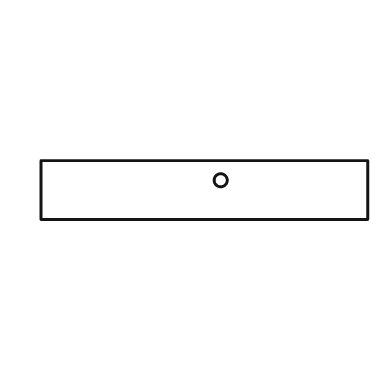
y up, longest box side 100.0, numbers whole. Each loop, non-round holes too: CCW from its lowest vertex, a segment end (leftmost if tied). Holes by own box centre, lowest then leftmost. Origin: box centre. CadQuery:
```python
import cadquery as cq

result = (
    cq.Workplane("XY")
    .moveTo(-50.0, -9.0)
    .lineTo(50.0, -9.0)
    .lineTo(50.0, 9.0)
    .lineTo(-50.0, 9.0)
    .close()
    .moveTo(5.0, 3.0)
    .circle(2.0)
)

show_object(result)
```